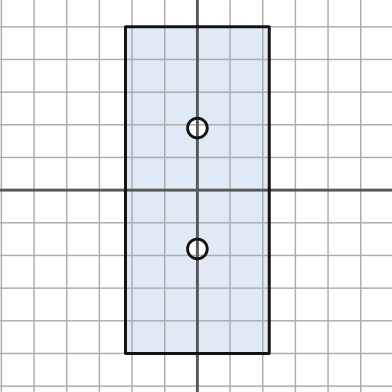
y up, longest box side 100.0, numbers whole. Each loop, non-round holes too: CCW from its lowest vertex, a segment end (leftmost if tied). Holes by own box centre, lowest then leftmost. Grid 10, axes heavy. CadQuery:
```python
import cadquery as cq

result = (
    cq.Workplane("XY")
    .moveTo(-22.0, -50.0)
    .lineTo(22.0, -50.0)
    .lineTo(22.0, 50.0)
    .lineTo(-22.0, 50.0)
    .close()
    .moveTo(0.0, -18.0)
    .circle(3.0)
    .moveTo(0.0, 19.0)
    .circle(3.0)
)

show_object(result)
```